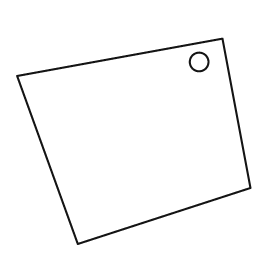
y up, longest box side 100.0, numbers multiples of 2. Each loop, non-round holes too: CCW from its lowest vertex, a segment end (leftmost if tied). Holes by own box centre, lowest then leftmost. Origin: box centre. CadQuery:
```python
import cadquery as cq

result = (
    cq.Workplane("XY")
    .moveTo(-24.0, -44.0)
    .lineTo(50.0, -20.0)
    .lineTo(38.0, 44.0)
    .lineTo(-50.0, 28.0)
    .close()
    .moveTo(28.0, 34.0)
    .circle(4.0)
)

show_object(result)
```